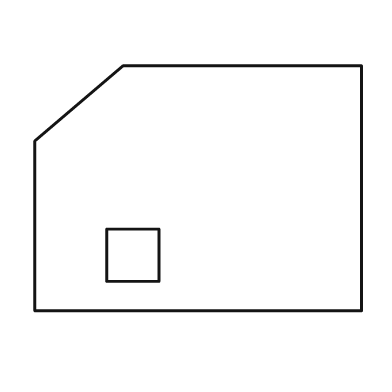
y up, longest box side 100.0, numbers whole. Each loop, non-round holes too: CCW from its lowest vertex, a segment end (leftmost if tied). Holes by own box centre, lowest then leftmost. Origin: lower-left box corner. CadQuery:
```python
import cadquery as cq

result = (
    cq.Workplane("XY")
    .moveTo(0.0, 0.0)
    .lineTo(100.0, 0.0)
    .lineTo(100.0, 75.0)
    .lineTo(27.0, 75.0)
    .lineTo(0.0, 52.0)
    .close()
    .moveTo(22.0, 9.0)
    .lineTo(38.0, 9.0)
    .lineTo(38.0, 25.0)
    .lineTo(22.0, 25.0)
    .close()
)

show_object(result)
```